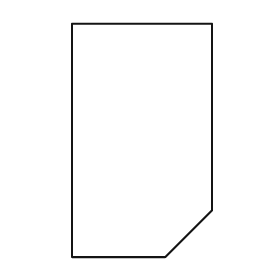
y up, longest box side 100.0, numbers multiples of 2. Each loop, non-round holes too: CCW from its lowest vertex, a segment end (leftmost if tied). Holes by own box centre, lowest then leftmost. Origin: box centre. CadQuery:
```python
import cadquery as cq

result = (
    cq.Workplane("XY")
    .moveTo(-30.0, -50.0)
    .lineTo(10.0, -50.0)
    .lineTo(30.0, -30.0)
    .lineTo(30.0, 50.0)
    .lineTo(-30.0, 50.0)
    .close()
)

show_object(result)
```